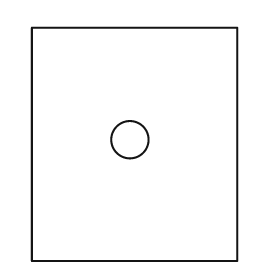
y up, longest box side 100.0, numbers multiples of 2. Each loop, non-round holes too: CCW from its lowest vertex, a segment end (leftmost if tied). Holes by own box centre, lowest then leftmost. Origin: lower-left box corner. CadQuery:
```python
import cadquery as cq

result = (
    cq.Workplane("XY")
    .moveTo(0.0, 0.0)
    .lineTo(88.0, 0.0)
    .lineTo(88.0, 100.0)
    .lineTo(0.0, 100.0)
    .close()
    .moveTo(42.0, 52.0)
    .circle(8.0)
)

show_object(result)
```